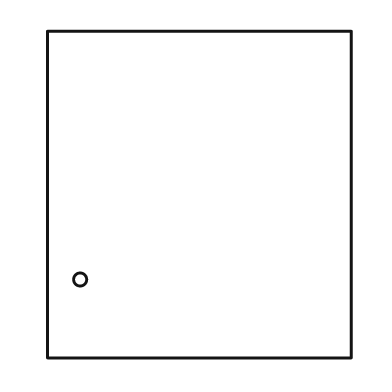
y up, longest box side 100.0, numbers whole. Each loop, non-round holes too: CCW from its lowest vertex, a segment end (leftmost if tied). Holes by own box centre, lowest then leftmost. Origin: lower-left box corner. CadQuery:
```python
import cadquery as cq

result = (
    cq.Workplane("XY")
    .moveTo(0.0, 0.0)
    .lineTo(93.0, 0.0)
    .lineTo(93.0, 100.0)
    .lineTo(0.0, 100.0)
    .close()
    .moveTo(10.0, 24.0)
    .circle(2.0)
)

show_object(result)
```